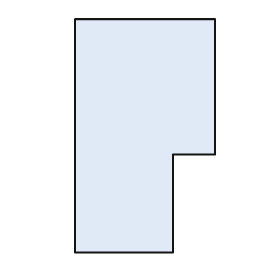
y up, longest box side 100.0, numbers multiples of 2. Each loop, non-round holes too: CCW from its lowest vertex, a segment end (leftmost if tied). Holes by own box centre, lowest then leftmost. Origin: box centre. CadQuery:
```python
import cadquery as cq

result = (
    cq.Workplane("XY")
    .moveTo(-30.0, -50.0)
    .lineTo(12.0, -50.0)
    .lineTo(12.0, -8.0)
    .lineTo(30.0, -8.0)
    .lineTo(30.0, 50.0)
    .lineTo(-30.0, 50.0)
    .close()
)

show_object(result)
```